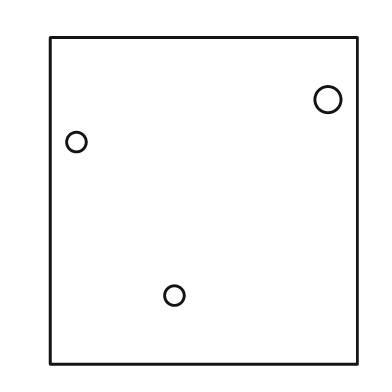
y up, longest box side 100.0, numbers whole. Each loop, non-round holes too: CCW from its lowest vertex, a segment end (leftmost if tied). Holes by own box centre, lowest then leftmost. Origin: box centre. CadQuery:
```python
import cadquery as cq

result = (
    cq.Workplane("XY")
    .moveTo(-47.0, -50.0)
    .lineTo(47.0, -50.0)
    .lineTo(47.0, 50.0)
    .lineTo(-47.0, 50.0)
    .close()
    .moveTo(-9.0, -29.0)
    .circle(3.0)
    .moveTo(-39.0, 18.0)
    .circle(3.0)
    .moveTo(38.0, 31.0)
    .circle(4.0)
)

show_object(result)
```